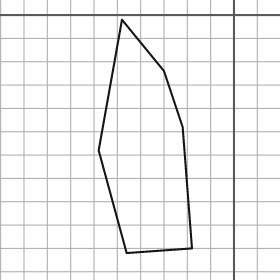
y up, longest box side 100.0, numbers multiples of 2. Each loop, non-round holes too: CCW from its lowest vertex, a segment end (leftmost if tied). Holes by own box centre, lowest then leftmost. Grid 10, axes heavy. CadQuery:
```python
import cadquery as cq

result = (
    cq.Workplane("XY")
    .moveTo(-46.0, -102.0)
    .lineTo(-18.0, -100.0)
    .lineTo(-22.0, -48.0)
    .lineTo(-30.0, -24.0)
    .lineTo(-48.0, -2.0)
    .lineTo(-58.0, -58.0)
    .close()
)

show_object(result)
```